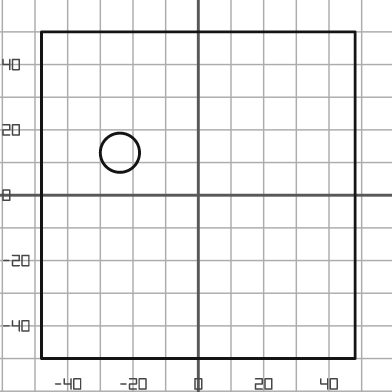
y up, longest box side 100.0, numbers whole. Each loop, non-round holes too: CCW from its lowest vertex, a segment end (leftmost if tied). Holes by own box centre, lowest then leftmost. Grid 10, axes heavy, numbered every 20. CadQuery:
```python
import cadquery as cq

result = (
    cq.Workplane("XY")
    .moveTo(-48.0, -50.0)
    .lineTo(48.0, -50.0)
    .lineTo(48.0, 50.0)
    .lineTo(-48.0, 50.0)
    .close()
    .moveTo(-24.0, 13.0)
    .circle(6.0)
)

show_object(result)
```